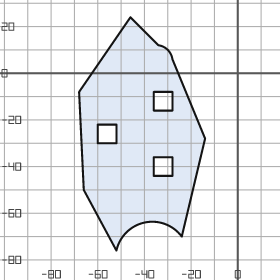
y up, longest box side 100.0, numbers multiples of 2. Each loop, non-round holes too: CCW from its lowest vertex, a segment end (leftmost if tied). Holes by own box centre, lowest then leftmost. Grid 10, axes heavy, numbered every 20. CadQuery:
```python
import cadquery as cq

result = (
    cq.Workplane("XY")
    .moveTo(-52.0, -76.0)
    .threePointArc((-40.0, -64.0), (-24.0, -70.0))
    .lineTo(-14.0, -28.0)
    .lineTo(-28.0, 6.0)
    .threePointArc((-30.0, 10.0), (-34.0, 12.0))
    .lineTo(-46.0, 24.0)
    .lineTo(-68.0, -8.0)
    .lineTo(-66.0, -50.0)
    .close()
    .moveTo(-36.0, -44.0)
    .lineTo(-28.0, -44.0)
    .lineTo(-28.0, -36.0)
    .lineTo(-36.0, -36.0)
    .close()
    .moveTo(-60.0, -30.0)
    .lineTo(-52.0, -30.0)
    .lineTo(-52.0, -22.0)
    .lineTo(-60.0, -22.0)
    .close()
    .moveTo(-36.0, -16.0)
    .lineTo(-28.0, -16.0)
    .lineTo(-28.0, -8.0)
    .lineTo(-36.0, -8.0)
    .close()
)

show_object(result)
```